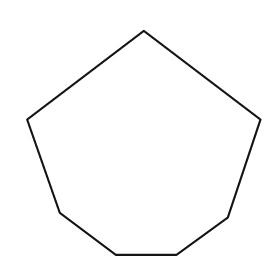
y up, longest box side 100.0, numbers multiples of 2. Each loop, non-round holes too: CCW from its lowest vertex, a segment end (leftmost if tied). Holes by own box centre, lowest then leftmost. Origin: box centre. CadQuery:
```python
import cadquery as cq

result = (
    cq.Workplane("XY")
    .moveTo(-12.0, -48.0)
    .lineTo(14.0, -48.0)
    .lineTo(36.0, -32.0)
    .lineTo(50.0, 10.0)
    .lineTo(0.0, 48.0)
    .lineTo(-50.0, 10.0)
    .lineTo(-36.0, -30.0)
    .close()
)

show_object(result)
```